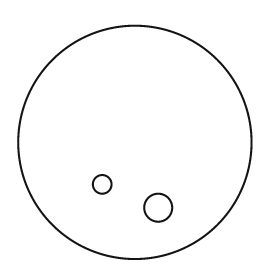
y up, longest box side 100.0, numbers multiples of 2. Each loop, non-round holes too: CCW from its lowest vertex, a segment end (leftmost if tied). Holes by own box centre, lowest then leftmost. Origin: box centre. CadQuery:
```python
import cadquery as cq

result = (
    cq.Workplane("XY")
    .moveTo(0.0, 0.0)
    .circle(50.0)
    .moveTo(10.0, -28.0)
    .circle(6.0)
    .moveTo(-14.0, -18.0)
    .circle(4.0)
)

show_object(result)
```